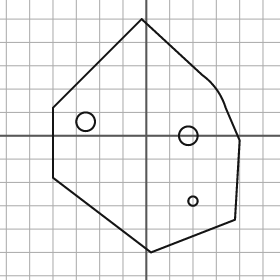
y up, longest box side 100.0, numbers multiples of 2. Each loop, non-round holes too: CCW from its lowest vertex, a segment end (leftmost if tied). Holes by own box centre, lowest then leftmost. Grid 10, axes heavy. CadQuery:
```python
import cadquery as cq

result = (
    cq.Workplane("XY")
    .moveTo(2.0, -50.0)
    .lineTo(38.0, -36.0)
    .lineTo(40.0, -2.0)
    .lineTo(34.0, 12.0)
    .threePointArc((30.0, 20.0), (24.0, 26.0))
    .lineTo(-2.0, 50.0)
    .lineTo(-40.0, 12.0)
    .lineTo(-40.0, -18.0)
    .close()
    .moveTo(20.0, -28.0)
    .circle(2.0)
    .moveTo(18.0, 0.0)
    .circle(4.0)
    .moveTo(-26.0, 6.0)
    .circle(4.0)
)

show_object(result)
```